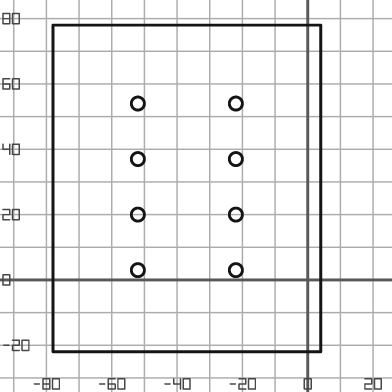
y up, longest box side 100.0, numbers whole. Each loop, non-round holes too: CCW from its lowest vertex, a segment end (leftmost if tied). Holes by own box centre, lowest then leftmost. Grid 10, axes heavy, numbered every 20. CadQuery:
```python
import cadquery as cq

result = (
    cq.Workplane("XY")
    .moveTo(-78.0, -22.0)
    .lineTo(4.0, -22.0)
    .lineTo(4.0, 78.0)
    .lineTo(-78.0, 78.0)
    .close()
    .moveTo(-52.0, 3.0)
    .circle(2.0)
    .moveTo(-22.0, 3.0)
    .circle(2.0)
    .moveTo(-52.0, 20.0)
    .circle(2.0)
    .moveTo(-22.0, 20.0)
    .circle(2.0)
    .moveTo(-52.0, 37.0)
    .circle(2.0)
    .moveTo(-22.0, 37.0)
    .circle(2.0)
    .moveTo(-52.0, 54.0)
    .circle(2.0)
    .moveTo(-22.0, 54.0)
    .circle(2.0)
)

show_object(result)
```